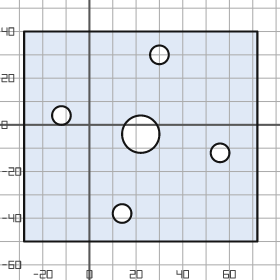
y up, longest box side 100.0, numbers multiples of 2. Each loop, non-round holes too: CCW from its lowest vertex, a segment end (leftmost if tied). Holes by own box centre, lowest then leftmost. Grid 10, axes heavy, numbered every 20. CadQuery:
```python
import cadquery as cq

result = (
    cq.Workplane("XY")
    .moveTo(-28.0, -50.0)
    .lineTo(72.0, -50.0)
    .lineTo(72.0, 40.0)
    .lineTo(-28.0, 40.0)
    .close()
    .moveTo(14.0, -38.0)
    .circle(4.0)
    .moveTo(56.0, -12.0)
    .circle(4.0)
    .moveTo(22.0, -4.0)
    .circle(8.0)
    .moveTo(-12.0, 4.0)
    .circle(4.0)
    .moveTo(30.0, 30.0)
    .circle(4.0)
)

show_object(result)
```